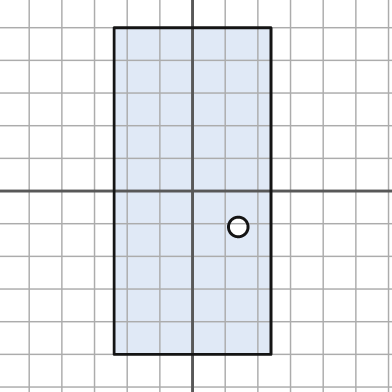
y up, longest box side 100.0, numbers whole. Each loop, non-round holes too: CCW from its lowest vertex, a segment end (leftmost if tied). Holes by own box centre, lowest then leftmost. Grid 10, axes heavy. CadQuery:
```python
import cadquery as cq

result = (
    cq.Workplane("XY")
    .moveTo(-24.0, -50.0)
    .lineTo(24.0, -50.0)
    .lineTo(24.0, 50.0)
    .lineTo(-24.0, 50.0)
    .close()
    .moveTo(14.0, -11.0)
    .circle(3.0)
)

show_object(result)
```